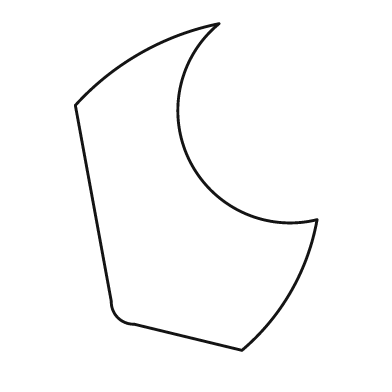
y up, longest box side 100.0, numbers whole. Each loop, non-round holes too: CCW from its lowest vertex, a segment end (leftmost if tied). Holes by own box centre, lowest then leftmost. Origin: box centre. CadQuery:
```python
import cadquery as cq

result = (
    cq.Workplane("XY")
    .moveTo(14.0, -50.0)
    .threePointArc((29.0, -32.0), (37.0, -10.0))
    .threePointArc((-2.0, 8.0), (7.0, 50.0))
    .threePointArc((-17.0, 41.0), (-37.0, 25.0))
    .lineTo(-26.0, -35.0)
    .threePointArc((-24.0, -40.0), (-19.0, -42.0))
    .close()
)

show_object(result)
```